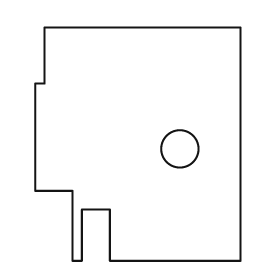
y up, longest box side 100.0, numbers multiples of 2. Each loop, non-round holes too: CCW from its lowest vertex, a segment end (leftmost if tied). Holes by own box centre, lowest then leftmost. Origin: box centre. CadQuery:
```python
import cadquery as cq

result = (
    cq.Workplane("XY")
    .moveTo(-28.0, -50.0)
    .lineTo(-24.0, -50.0)
    .lineTo(-24.0, -28.0)
    .lineTo(-12.0, -28.0)
    .lineTo(-12.0, -50.0)
    .lineTo(44.0, -50.0)
    .lineTo(44.0, 50.0)
    .lineTo(-40.0, 50.0)
    .lineTo(-40.0, 26.0)
    .lineTo(-44.0, 26.0)
    .lineTo(-44.0, -20.0)
    .lineTo(-28.0, -20.0)
    .close()
    .moveTo(18.0, -2.0)
    .circle(8.0)
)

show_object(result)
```